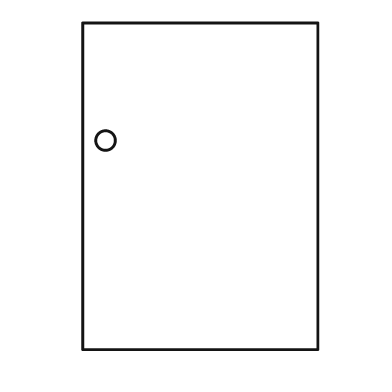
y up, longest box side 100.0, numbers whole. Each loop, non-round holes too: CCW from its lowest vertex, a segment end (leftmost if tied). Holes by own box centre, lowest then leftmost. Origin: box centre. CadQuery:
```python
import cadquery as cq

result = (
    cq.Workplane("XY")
    .moveTo(-36.0, -50.0)
    .lineTo(36.0, -50.0)
    .lineTo(36.0, 50.0)
    .lineTo(-36.0, 50.0)
    .close()
    .moveTo(-29.0, 14.0)
    .circle(3.0)
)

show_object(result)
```